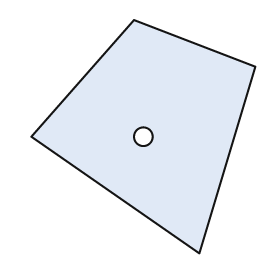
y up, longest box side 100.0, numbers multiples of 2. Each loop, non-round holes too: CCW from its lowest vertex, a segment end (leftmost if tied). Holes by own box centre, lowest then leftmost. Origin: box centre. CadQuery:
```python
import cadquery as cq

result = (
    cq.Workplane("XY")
    .moveTo(24.0, -50.0)
    .lineTo(48.0, 30.0)
    .lineTo(-4.0, 50.0)
    .lineTo(-48.0, 0.0)
    .close()
    .moveTo(0.0, 0.0)
    .circle(4.0)
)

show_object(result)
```